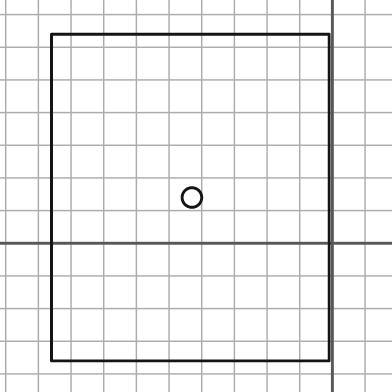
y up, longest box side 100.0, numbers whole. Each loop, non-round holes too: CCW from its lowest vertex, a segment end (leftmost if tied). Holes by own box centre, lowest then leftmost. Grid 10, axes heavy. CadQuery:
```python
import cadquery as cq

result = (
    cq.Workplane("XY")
    .moveTo(-86.0, -36.0)
    .lineTo(-1.0, -36.0)
    .lineTo(-1.0, 64.0)
    .lineTo(-86.0, 64.0)
    .close()
    .moveTo(-43.0, 14.0)
    .circle(3.0)
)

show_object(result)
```